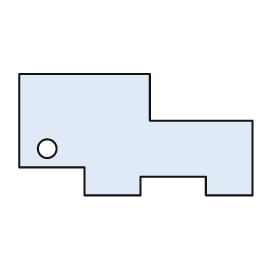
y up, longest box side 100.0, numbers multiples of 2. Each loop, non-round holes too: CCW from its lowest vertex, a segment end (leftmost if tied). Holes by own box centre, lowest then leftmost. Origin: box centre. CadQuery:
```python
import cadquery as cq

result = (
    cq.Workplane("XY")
    .moveTo(-22.0, -26.0)
    .lineTo(2.0, -26.0)
    .lineTo(2.0, -18.0)
    .lineTo(30.0, -18.0)
    .lineTo(30.0, -26.0)
    .lineTo(50.0, -26.0)
    .lineTo(50.0, 6.0)
    .lineTo(6.0, 6.0)
    .lineTo(6.0, 26.0)
    .lineTo(-50.0, 26.0)
    .lineTo(-50.0, -14.0)
    .lineTo(-22.0, -14.0)
    .close()
    .moveTo(-38.0, -6.0)
    .circle(4.0)
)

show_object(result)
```